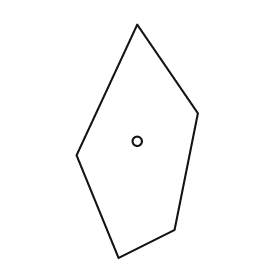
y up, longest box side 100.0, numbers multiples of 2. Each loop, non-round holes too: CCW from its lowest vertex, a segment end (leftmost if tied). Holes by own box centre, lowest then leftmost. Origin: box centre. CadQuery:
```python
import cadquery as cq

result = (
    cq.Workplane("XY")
    .moveTo(-8.0, -50.0)
    .lineTo(16.0, -38.0)
    .lineTo(26.0, 12.0)
    .lineTo(0.0, 50.0)
    .lineTo(-26.0, -6.0)
    .close()
    .moveTo(0.0, 0.0)
    .circle(2.0)
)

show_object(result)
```